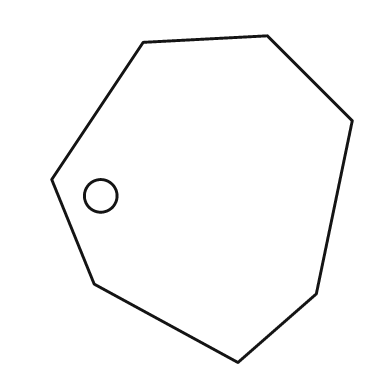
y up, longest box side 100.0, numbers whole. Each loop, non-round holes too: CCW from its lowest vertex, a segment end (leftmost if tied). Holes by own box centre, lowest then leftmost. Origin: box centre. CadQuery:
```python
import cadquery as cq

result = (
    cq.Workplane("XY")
    .moveTo(11.0, -50.0)
    .lineTo(35.0, -29.0)
    .lineTo(46.0, 24.0)
    .lineTo(20.0, 50.0)
    .lineTo(-18.0, 48.0)
    .lineTo(-46.0, 6.0)
    .lineTo(-33.0, -26.0)
    .close()
    .moveTo(-31.0, 1.0)
    .circle(5.0)
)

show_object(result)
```